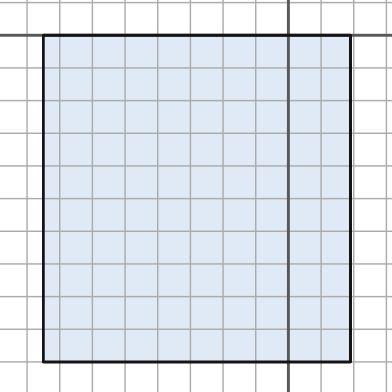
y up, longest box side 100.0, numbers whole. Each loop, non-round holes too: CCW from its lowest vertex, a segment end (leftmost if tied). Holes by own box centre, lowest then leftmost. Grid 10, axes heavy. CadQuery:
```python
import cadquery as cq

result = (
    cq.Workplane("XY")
    .moveTo(-75.0, -100.0)
    .lineTo(19.0, -100.0)
    .lineTo(19.0, 0.0)
    .lineTo(-75.0, 0.0)
    .close()
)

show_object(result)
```